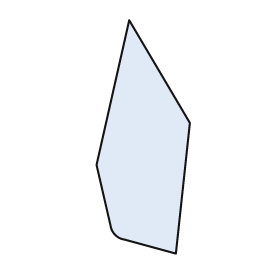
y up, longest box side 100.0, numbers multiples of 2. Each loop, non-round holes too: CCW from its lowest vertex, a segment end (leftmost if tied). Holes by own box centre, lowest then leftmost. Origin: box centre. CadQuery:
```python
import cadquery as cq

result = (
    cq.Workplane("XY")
    .moveTo(14.0, -50.0)
    .lineTo(20.0, 6.0)
    .lineTo(-6.0, 50.0)
    .lineTo(-20.0, -12.0)
    .lineTo(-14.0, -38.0)
    .threePointArc((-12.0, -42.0), (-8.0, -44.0))
    .close()
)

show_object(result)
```